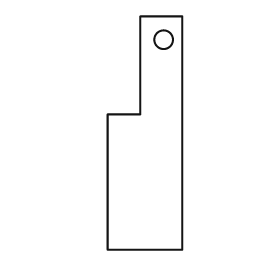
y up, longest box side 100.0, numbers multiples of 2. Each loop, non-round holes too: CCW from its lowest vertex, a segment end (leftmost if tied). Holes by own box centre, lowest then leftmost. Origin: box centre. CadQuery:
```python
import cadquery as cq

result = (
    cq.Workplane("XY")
    .moveTo(-16.0, -50.0)
    .lineTo(16.0, -50.0)
    .lineTo(16.0, 50.0)
    .lineTo(-2.0, 50.0)
    .lineTo(-2.0, 8.0)
    .lineTo(-16.0, 8.0)
    .close()
    .moveTo(8.0, 40.0)
    .circle(4.0)
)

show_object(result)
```